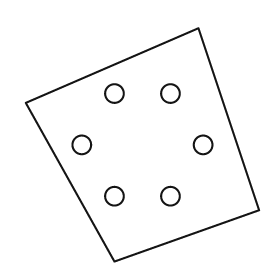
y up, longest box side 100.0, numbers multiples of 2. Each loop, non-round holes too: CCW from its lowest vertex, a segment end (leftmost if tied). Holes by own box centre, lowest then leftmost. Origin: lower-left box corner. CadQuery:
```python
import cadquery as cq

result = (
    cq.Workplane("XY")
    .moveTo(38.0, 0.0)
    .lineTo(100.0, 22.0)
    .lineTo(74.0, 100.0)
    .lineTo(0.0, 68.0)
    .close()
    .moveTo(38.0, 28.0)
    .circle(4.0)
    .moveTo(62.0, 28.0)
    .circle(4.0)
    .moveTo(24.0, 50.0)
    .circle(4.0)
    .moveTo(76.0, 50.0)
    .circle(4.0)
    .moveTo(38.0, 72.0)
    .circle(4.0)
    .moveTo(62.0, 72.0)
    .circle(4.0)
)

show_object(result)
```